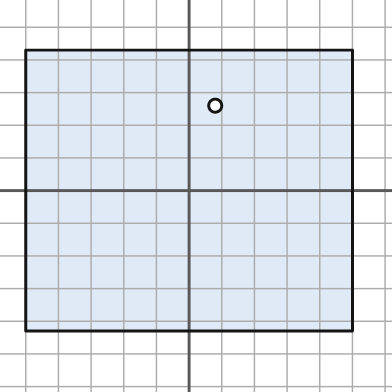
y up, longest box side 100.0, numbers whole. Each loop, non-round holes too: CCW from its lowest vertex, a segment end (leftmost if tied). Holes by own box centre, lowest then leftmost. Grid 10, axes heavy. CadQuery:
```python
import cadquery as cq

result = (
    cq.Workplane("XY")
    .moveTo(-50.0, -43.0)
    .lineTo(50.0, -43.0)
    .lineTo(50.0, 43.0)
    .lineTo(-50.0, 43.0)
    .close()
    .moveTo(8.0, 26.0)
    .circle(2.0)
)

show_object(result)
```